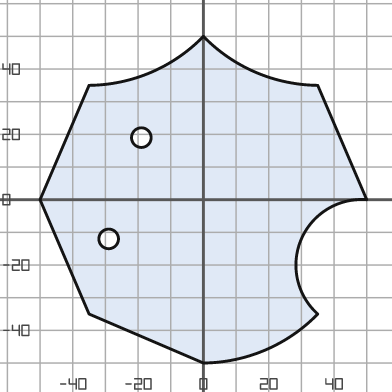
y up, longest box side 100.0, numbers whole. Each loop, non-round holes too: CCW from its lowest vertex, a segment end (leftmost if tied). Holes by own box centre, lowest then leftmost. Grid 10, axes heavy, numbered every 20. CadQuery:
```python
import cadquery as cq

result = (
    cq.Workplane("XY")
    .moveTo(0.0, -50.0)
    .threePointArc((19.0, -46.0), (35.0, -35.0))
    .threePointArc((30.0, -12.0), (50.0, 0.0))
    .lineTo(35.0, 35.0)
    .threePointArc((16.0, 39.0), (0.0, 50.0))
    .threePointArc((-16.0, 39.0), (-35.0, 35.0))
    .lineTo(-50.0, 0.0)
    .lineTo(-35.0, -35.0)
    .close()
    .moveTo(-29.0, -12.0)
    .circle(3.0)
    .moveTo(-19.0, 19.0)
    .circle(3.0)
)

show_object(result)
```